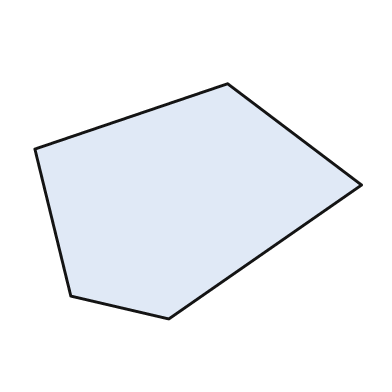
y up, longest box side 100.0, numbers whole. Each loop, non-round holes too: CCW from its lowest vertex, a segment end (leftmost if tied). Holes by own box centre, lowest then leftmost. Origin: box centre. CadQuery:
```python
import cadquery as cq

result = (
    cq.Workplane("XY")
    .moveTo(-9.0, -36.0)
    .lineTo(50.0, 5.0)
    .lineTo(9.0, 36.0)
    .lineTo(-50.0, 16.0)
    .lineTo(-39.0, -29.0)
    .close()
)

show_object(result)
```